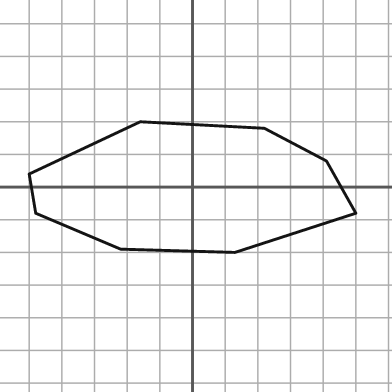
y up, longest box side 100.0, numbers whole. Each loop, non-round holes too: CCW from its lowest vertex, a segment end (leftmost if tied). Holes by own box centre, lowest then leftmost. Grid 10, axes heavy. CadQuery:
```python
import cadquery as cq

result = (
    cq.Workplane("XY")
    .moveTo(13.0, -20.0)
    .lineTo(50.0, -8.0)
    .lineTo(41.0, 8.0)
    .lineTo(22.0, 18.0)
    .lineTo(-16.0, 20.0)
    .lineTo(-50.0, 4.0)
    .lineTo(-48.0, -8.0)
    .lineTo(-22.0, -19.0)
    .close()
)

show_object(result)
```